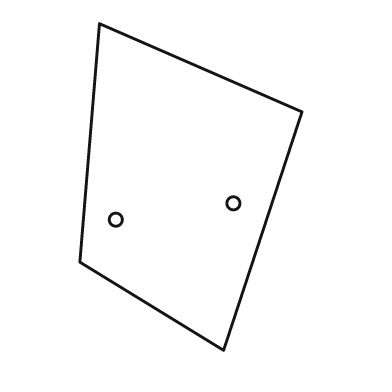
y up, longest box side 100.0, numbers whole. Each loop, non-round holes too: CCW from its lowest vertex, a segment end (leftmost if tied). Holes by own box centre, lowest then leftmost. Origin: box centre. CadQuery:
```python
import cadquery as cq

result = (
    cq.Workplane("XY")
    .moveTo(10.0, -50.0)
    .lineTo(34.0, 23.0)
    .lineTo(-28.0, 50.0)
    .lineTo(-34.0, -23.0)
    .close()
    .moveTo(-23.0, -10.0)
    .circle(2.0)
    .moveTo(13.0, -5.0)
    .circle(2.0)
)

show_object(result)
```